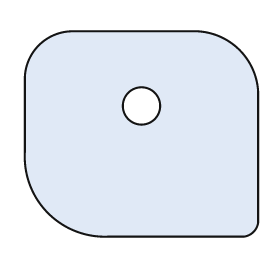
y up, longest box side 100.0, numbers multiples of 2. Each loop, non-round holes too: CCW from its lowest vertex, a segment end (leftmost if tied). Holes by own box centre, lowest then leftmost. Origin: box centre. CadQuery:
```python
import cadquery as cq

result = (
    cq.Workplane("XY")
    .moveTo(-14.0, -44.0)
    .lineTo(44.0, -44.0)
    .threePointArc((48.0, -42.0), (50.0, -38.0))
    .lineTo(50.0, 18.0)
    .threePointArc((42.0, 36.0), (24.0, 44.0))
    .lineTo(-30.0, 44.0)
    .threePointArc((-44.0, 38.0), (-50.0, 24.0))
    .lineTo(-50.0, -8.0)
    .threePointArc((-40.0, -34.0), (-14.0, -44.0))
    .close()
    .moveTo(0.0, 12.0)
    .circle(8.0)
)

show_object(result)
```